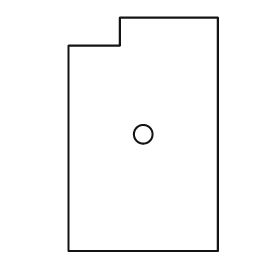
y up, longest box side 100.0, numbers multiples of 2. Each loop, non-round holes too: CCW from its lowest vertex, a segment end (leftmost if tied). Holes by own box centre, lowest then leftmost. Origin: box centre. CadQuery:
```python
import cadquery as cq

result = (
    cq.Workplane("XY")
    .moveTo(-32.0, -50.0)
    .lineTo(32.0, -50.0)
    .lineTo(32.0, 50.0)
    .lineTo(-10.0, 50.0)
    .lineTo(-10.0, 38.0)
    .lineTo(-32.0, 38.0)
    .close()
    .moveTo(0.0, 0.0)
    .circle(4.0)
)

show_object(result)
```